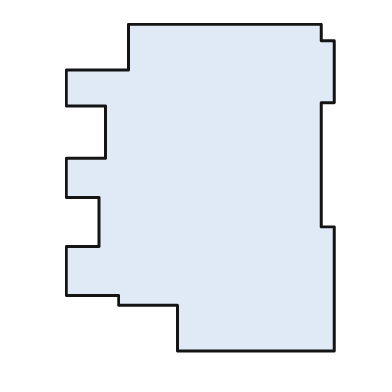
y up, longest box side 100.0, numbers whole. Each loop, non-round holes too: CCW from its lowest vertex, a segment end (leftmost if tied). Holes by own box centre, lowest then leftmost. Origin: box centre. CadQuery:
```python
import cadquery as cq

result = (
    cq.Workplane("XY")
    .moveTo(-7.0, -50.0)
    .lineTo(41.0, -50.0)
    .lineTo(41.0, -12.0)
    .lineTo(37.0, -12.0)
    .lineTo(37.0, 26.0)
    .lineTo(41.0, 26.0)
    .lineTo(41.0, 45.0)
    .lineTo(37.0, 45.0)
    .lineTo(37.0, 50.0)
    .lineTo(-22.0, 50.0)
    .lineTo(-22.0, 36.0)
    .lineTo(-41.0, 36.0)
    .lineTo(-41.0, 25.0)
    .lineTo(-29.0, 25.0)
    .lineTo(-29.0, 9.0)
    .lineTo(-41.0, 9.0)
    .lineTo(-41.0, -3.0)
    .lineTo(-31.0, -3.0)
    .lineTo(-31.0, -18.0)
    .lineTo(-41.0, -18.0)
    .lineTo(-41.0, -33.0)
    .lineTo(-25.0, -33.0)
    .lineTo(-25.0, -36.0)
    .lineTo(-7.0, -36.0)
    .close()
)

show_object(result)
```